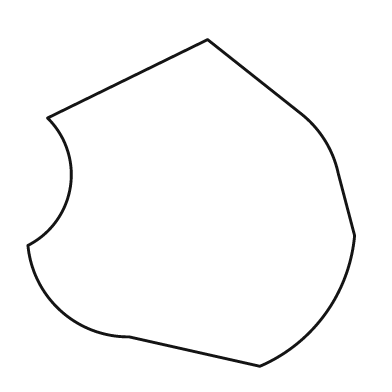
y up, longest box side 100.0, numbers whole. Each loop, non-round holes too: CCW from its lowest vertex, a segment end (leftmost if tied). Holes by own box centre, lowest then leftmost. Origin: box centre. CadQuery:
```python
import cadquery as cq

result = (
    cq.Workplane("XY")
    .moveTo(21.0, -50.0)
    .threePointArc((41.0, -34.0), (50.0, -10.0))
    .lineTo(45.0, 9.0)
    .threePointArc((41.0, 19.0), (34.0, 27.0))
    .lineTo(5.0, 50.0)
    .lineTo(-44.0, 26.0)
    .threePointArc((-37.0, 5.0), (-50.0, -13.0))
    .threePointArc((-40.0, -33.0), (-19.0, -41.0))
    .close()
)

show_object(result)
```